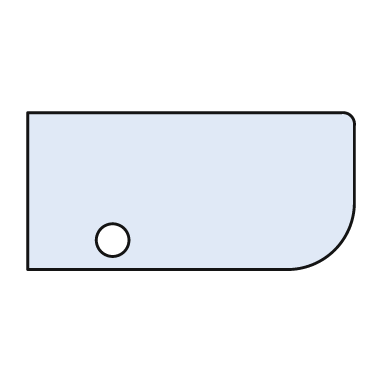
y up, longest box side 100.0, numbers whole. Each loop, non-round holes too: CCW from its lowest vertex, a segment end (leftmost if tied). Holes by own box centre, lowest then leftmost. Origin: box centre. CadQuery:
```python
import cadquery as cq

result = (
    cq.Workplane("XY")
    .moveTo(-50.0, -24.0)
    .lineTo(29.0, -24.0)
    .threePointArc((44.0, -18.0), (50.0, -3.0))
    .lineTo(50.0, 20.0)
    .threePointArc((49.0, 23.0), (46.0, 24.0))
    .lineTo(-50.0, 24.0)
    .close()
    .moveTo(-24.0, -15.0)
    .circle(5.0)
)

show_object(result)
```